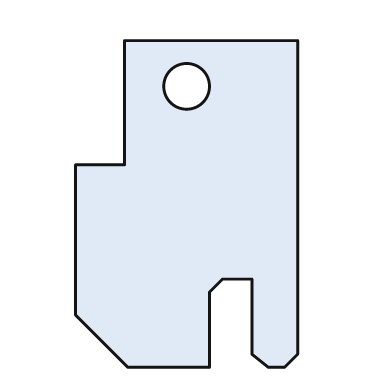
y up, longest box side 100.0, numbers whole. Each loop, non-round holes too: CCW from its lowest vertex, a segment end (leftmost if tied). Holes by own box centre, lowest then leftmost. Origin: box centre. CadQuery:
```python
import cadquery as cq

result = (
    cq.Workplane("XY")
    .moveTo(-18.0, -50.0)
    .lineTo(7.0, -50.0)
    .lineTo(7.0, -27.0)
    .lineTo(11.0, -23.0)
    .lineTo(20.0, -23.0)
    .lineTo(20.0, -46.0)
    .lineTo(25.0, -50.0)
    .lineTo(30.0, -50.0)
    .lineTo(34.0, -46.0)
    .lineTo(34.0, 50.0)
    .lineTo(-19.0, 50.0)
    .lineTo(-19.0, 12.0)
    .lineTo(-34.0, 12.0)
    .lineTo(-34.0, -34.0)
    .close()
    .moveTo(0.0, 36.0)
    .circle(7.0)
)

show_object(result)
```